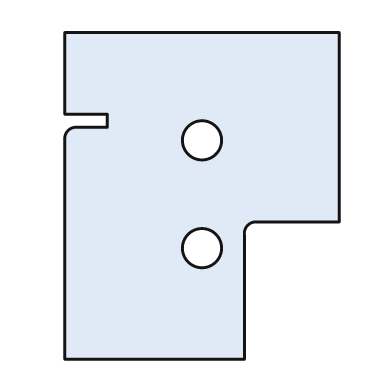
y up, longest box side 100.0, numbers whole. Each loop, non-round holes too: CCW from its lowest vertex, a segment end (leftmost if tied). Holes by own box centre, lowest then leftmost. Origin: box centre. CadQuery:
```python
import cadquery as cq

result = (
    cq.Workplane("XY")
    .moveTo(-42.0, -50.0)
    .lineTo(13.0, -50.0)
    .lineTo(13.0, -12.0)
    .threePointArc((14.0, -9.0), (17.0, -8.0))
    .lineTo(42.0, -8.0)
    .lineTo(42.0, 50.0)
    .lineTo(-42.0, 50.0)
    .lineTo(-42.0, 25.0)
    .lineTo(-29.0, 25.0)
    .lineTo(-29.0, 21.0)
    .lineTo(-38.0, 21.0)
    .threePointArc((-41.0, 20.0), (-42.0, 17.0))
    .close()
    .moveTo(0.0, -16.0)
    .circle(6.0)
    .moveTo(0.0, 17.0)
    .circle(6.0)
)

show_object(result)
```